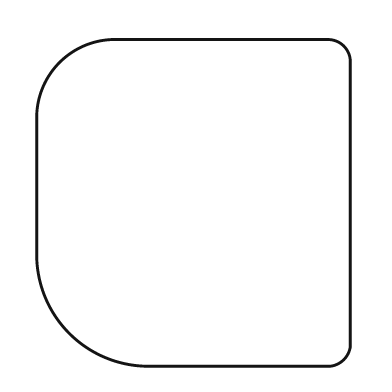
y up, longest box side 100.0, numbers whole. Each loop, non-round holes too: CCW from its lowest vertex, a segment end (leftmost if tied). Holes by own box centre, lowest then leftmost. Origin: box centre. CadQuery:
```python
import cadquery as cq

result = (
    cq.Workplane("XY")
    .moveTo(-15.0, -50.0)
    .lineTo(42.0, -50.0)
    .threePointArc((46.0, -48.0), (48.0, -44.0))
    .lineTo(48.0, 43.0)
    .threePointArc((46.0, 48.0), (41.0, 50.0))
    .lineTo(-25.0, 50.0)
    .threePointArc((-41.0, 43.0), (-48.0, 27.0))
    .lineTo(-48.0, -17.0)
    .threePointArc((-38.0, -40.0), (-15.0, -50.0))
    .close()
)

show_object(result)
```